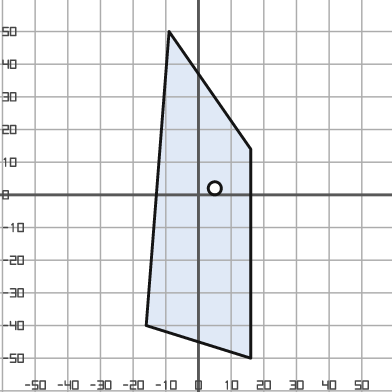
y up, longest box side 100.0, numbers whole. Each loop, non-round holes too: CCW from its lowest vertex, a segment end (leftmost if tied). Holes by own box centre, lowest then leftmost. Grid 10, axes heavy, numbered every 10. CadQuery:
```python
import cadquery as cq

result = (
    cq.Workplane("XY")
    .moveTo(16.0, -50.0)
    .lineTo(16.0, 14.0)
    .lineTo(-9.0, 50.0)
    .lineTo(-16.0, -40.0)
    .close()
    .moveTo(5.0, 2.0)
    .circle(2.0)
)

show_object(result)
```